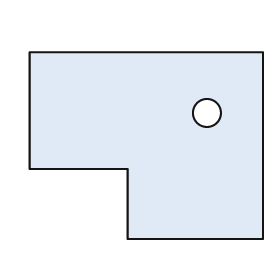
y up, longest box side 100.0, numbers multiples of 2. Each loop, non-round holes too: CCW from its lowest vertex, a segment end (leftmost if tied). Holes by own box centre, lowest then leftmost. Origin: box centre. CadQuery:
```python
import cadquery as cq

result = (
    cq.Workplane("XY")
    .moveTo(-8.0, -40.0)
    .lineTo(50.0, -40.0)
    .lineTo(50.0, 40.0)
    .lineTo(-50.0, 40.0)
    .lineTo(-50.0, -10.0)
    .lineTo(-8.0, -10.0)
    .close()
    .moveTo(26.0, 14.0)
    .circle(6.0)
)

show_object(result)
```